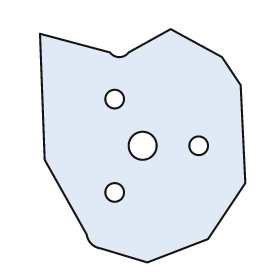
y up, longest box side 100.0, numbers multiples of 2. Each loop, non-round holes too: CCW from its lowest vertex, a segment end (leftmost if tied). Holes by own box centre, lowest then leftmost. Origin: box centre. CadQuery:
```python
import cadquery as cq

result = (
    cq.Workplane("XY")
    .moveTo(2.0, -50.0)
    .lineTo(28.0, -40.0)
    .lineTo(44.0, -16.0)
    .lineTo(42.0, 26.0)
    .lineTo(34.0, 38.0)
    .lineTo(12.0, 50.0)
    .lineTo(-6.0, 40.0)
    .threePointArc((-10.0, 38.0), (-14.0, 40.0))
    .lineTo(-44.0, 48.0)
    .lineTo(-42.0, -6.0)
    .lineTo(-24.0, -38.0)
    .threePointArc((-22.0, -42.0), (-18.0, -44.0))
    .close()
    .moveTo(-12.0, -20.0)
    .circle(4.0)
    .moveTo(0.0, 0.0)
    .circle(6.0)
    .moveTo(24.0, 0.0)
    .circle(4.0)
    .moveTo(-12.0, 20.0)
    .circle(4.0)
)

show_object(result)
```